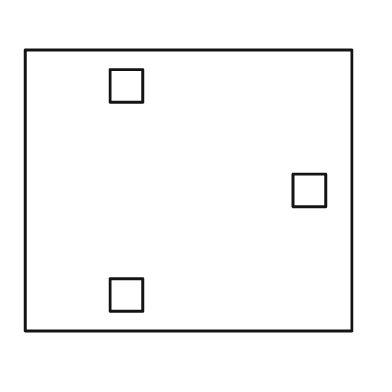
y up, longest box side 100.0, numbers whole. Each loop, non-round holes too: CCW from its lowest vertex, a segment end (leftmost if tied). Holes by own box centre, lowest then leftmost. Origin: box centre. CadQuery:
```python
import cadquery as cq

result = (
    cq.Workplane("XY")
    .moveTo(-50.0, -43.0)
    .lineTo(50.0, -43.0)
    .lineTo(50.0, 43.0)
    .lineTo(-50.0, 43.0)
    .close()
    .moveTo(-24.0, -37.0)
    .lineTo(-14.0, -37.0)
    .lineTo(-14.0, -27.0)
    .lineTo(-24.0, -27.0)
    .close()
    .moveTo(32.0, -5.0)
    .lineTo(42.0, -5.0)
    .lineTo(42.0, 5.0)
    .lineTo(32.0, 5.0)
    .close()
    .moveTo(-24.0, 27.0)
    .lineTo(-14.0, 27.0)
    .lineTo(-14.0, 37.0)
    .lineTo(-24.0, 37.0)
    .close()
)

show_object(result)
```